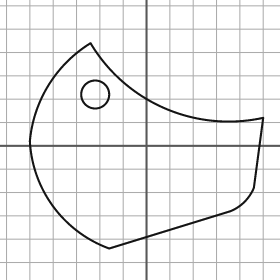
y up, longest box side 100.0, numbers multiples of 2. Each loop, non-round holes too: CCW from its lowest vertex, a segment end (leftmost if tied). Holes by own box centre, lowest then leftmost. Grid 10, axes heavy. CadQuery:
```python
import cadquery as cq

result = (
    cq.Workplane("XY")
    .moveTo(-16.0, -44.0)
    .lineTo(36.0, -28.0)
    .threePointArc((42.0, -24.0), (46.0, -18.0))
    .lineTo(50.0, 12.0)
    .threePointArc((8.0, 16.0), (-24.0, 44.0))
    .threePointArc((-42.0, 26.0), (-50.0, 2.0))
    .threePointArc((-40.0, -26.0), (-16.0, -44.0))
    .close()
    .moveTo(-22.0, 22.0)
    .circle(6.0)
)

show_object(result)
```